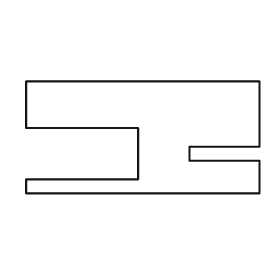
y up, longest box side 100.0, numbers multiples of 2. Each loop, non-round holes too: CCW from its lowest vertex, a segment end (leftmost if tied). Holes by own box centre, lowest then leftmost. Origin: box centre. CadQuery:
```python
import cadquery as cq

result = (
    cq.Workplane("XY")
    .moveTo(-50.0, -24.0)
    .lineTo(50.0, -24.0)
    .lineTo(50.0, -10.0)
    .lineTo(20.0, -10.0)
    .lineTo(20.0, -4.0)
    .lineTo(50.0, -4.0)
    .lineTo(50.0, 24.0)
    .lineTo(-50.0, 24.0)
    .lineTo(-50.0, 4.0)
    .lineTo(-2.0, 4.0)
    .lineTo(-2.0, -18.0)
    .lineTo(-50.0, -18.0)
    .close()
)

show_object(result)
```